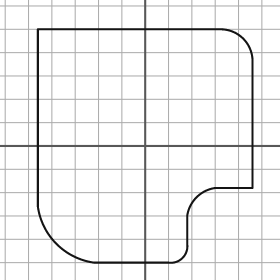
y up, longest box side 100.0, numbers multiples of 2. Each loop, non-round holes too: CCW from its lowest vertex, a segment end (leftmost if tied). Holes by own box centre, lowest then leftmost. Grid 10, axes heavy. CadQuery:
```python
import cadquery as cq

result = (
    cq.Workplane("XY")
    .moveTo(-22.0, -50.0)
    .lineTo(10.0, -50.0)
    .threePointArc((16.0, -48.0), (18.0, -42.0))
    .lineTo(18.0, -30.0)
    .threePointArc((22.0, -22.0), (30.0, -18.0))
    .lineTo(46.0, -18.0)
    .lineTo(46.0, 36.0)
    .threePointArc((42.0, 46.0), (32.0, 50.0))
    .lineTo(-46.0, 50.0)
    .lineTo(-46.0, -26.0)
    .threePointArc((-38.0, -42.0), (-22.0, -50.0))
    .close()
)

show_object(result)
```